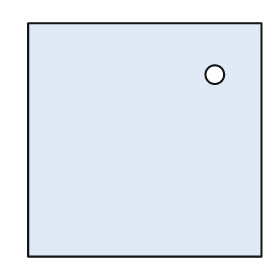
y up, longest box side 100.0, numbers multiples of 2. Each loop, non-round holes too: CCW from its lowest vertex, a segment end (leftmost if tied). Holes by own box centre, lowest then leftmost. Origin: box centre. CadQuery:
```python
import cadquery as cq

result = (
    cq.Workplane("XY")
    .moveTo(-50.0, -50.0)
    .lineTo(50.0, -50.0)
    .lineTo(50.0, 50.0)
    .lineTo(-50.0, 50.0)
    .close()
    .moveTo(30.0, 28.0)
    .circle(4.0)
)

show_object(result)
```